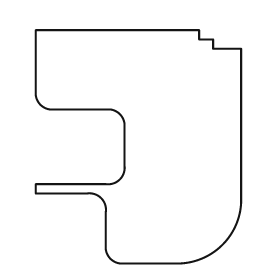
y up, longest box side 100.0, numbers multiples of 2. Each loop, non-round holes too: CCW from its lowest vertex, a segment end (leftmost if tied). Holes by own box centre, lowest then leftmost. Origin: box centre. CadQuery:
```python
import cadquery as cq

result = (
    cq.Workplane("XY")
    .moveTo(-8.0, -50.0)
    .lineTo(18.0, -50.0)
    .threePointArc((36.0, -42.0), (44.0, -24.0))
    .lineTo(44.0, 42.0)
    .lineTo(32.0, 42.0)
    .lineTo(32.0, 46.0)
    .lineTo(26.0, 46.0)
    .lineTo(26.0, 50.0)
    .lineTo(-44.0, 50.0)
    .lineTo(-44.0, 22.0)
    .threePointArc((-42.0, 18.0), (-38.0, 16.0))
    .lineTo(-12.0, 16.0)
    .threePointArc((-8.0, 14.0), (-6.0, 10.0))
    .lineTo(-6.0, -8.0)
    .threePointArc((-8.0, -14.0), (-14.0, -16.0))
    .lineTo(-44.0, -16.0)
    .lineTo(-44.0, -20.0)
    .lineTo(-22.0, -20.0)
    .threePointArc((-16.0, -22.0), (-14.0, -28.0))
    .lineTo(-14.0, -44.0)
    .threePointArc((-12.0, -48.0), (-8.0, -50.0))
    .close()
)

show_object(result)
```